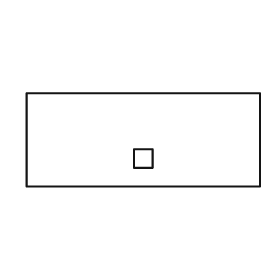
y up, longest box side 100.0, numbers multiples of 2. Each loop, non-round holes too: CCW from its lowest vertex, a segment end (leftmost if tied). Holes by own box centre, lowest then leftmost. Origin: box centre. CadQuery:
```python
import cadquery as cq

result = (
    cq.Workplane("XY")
    .moveTo(-50.0, -20.0)
    .lineTo(50.0, -20.0)
    .lineTo(50.0, 20.0)
    .lineTo(-50.0, 20.0)
    .close()
    .moveTo(-4.0, -12.0)
    .lineTo(4.0, -12.0)
    .lineTo(4.0, -4.0)
    .lineTo(-4.0, -4.0)
    .close()
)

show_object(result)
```